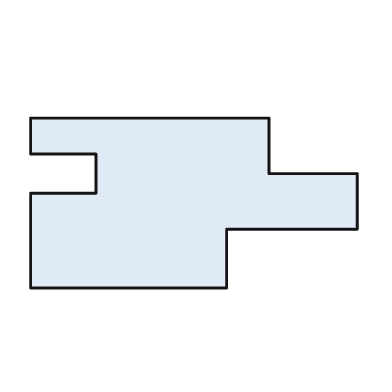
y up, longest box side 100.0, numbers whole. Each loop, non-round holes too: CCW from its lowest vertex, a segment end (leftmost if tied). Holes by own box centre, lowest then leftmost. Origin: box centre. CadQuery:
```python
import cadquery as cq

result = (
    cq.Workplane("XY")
    .moveTo(-50.0, -26.0)
    .lineTo(10.0, -26.0)
    .lineTo(10.0, -8.0)
    .lineTo(50.0, -8.0)
    .lineTo(50.0, 9.0)
    .lineTo(23.0, 9.0)
    .lineTo(23.0, 26.0)
    .lineTo(-50.0, 26.0)
    .lineTo(-50.0, 15.0)
    .lineTo(-30.0, 15.0)
    .lineTo(-30.0, 3.0)
    .lineTo(-50.0, 3.0)
    .close()
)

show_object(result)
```